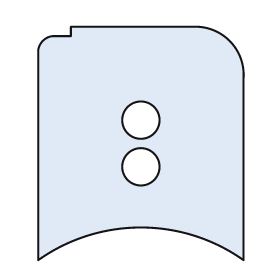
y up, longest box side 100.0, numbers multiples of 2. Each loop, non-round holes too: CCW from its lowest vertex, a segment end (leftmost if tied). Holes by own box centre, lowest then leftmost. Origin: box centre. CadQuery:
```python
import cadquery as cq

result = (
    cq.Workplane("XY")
    .moveTo(-44.0, -50.0)
    .threePointArc((0.0, -36.0), (44.0, -50.0))
    .lineTo(44.0, 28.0)
    .threePointArc((38.0, 44.0), (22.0, 50.0))
    .lineTo(-30.0, 50.0)
    .lineTo(-30.0, 46.0)
    .lineTo(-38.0, 46.0)
    .threePointArc((-42.0, 44.0), (-44.0, 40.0))
    .close()
    .moveTo(0.0, -10.0)
    .circle(8.0)
    .moveTo(0.0, 10.0)
    .circle(8.0)
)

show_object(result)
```